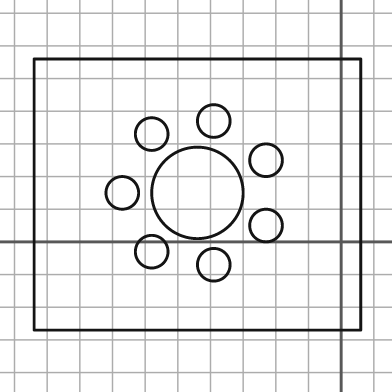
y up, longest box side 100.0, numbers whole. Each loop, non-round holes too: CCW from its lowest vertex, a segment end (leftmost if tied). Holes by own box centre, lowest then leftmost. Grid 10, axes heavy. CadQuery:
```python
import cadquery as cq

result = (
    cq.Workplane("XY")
    .moveTo(-94.0, -27.0)
    .lineTo(6.0, -27.0)
    .lineTo(6.0, 56.0)
    .lineTo(-94.0, 56.0)
    .close()
    .moveTo(-39.0, -7.0)
    .circle(5.0)
    .moveTo(-58.0, -3.0)
    .circle(5.0)
    .moveTo(-23.0, 5.0)
    .circle(5.0)
    .moveTo(-67.0, 15.0)
    .circle(5.0)
    .moveTo(-44.0, 15.0)
    .circle(14.0)
    .moveTo(-23.0, 25.0)
    .circle(5.0)
    .moveTo(-58.0, 33.0)
    .circle(5.0)
    .moveTo(-39.0, 37.0)
    .circle(5.0)
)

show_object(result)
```